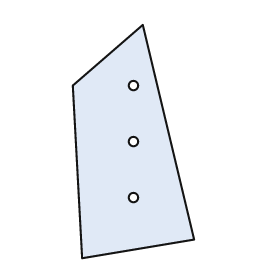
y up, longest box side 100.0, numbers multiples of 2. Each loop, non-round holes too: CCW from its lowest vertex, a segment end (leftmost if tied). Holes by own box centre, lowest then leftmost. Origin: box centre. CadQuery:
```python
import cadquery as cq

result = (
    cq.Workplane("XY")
    .moveTo(-22.0, -50.0)
    .lineTo(26.0, -42.0)
    .lineTo(4.0, 50.0)
    .lineTo(-26.0, 24.0)
    .close()
    .moveTo(0.0, -24.0)
    .circle(2.0)
    .moveTo(0.0, 0.0)
    .circle(2.0)
    .moveTo(0.0, 24.0)
    .circle(2.0)
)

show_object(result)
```